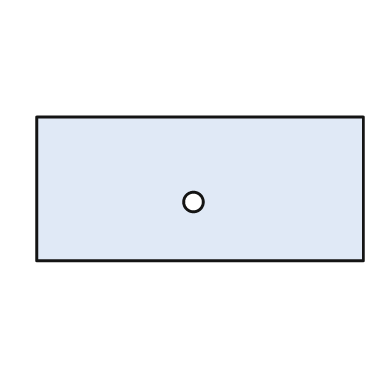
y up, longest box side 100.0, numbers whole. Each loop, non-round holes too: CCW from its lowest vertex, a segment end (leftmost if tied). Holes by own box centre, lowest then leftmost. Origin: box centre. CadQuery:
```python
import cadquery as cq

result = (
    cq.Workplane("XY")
    .moveTo(-50.0, -22.0)
    .lineTo(50.0, -22.0)
    .lineTo(50.0, 22.0)
    .lineTo(-50.0, 22.0)
    .close()
    .moveTo(-2.0, -4.0)
    .circle(3.0)
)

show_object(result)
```